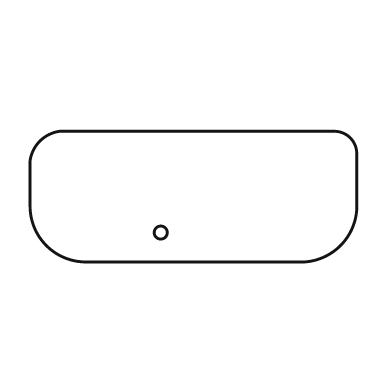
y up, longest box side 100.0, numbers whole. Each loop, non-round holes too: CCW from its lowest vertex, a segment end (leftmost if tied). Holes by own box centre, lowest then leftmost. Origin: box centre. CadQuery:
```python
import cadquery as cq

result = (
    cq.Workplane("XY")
    .moveTo(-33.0, -20.0)
    .lineTo(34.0, -20.0)
    .threePointArc((45.0, -15.0), (50.0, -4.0))
    .lineTo(50.0, 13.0)
    .threePointArc((48.0, 18.0), (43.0, 20.0))
    .lineTo(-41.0, 20.0)
    .threePointArc((-47.0, 17.0), (-50.0, 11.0))
    .lineTo(-50.0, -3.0)
    .threePointArc((-45.0, -15.0), (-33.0, -20.0))
    .close()
    .moveTo(-10.0, -11.0)
    .circle(2.0)
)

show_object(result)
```